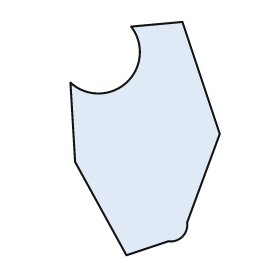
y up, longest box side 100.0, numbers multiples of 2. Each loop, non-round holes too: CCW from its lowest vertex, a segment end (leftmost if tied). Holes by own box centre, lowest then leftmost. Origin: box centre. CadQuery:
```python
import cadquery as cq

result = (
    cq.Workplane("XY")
    .moveTo(-8.0, -50.0)
    .lineTo(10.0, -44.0)
    .threePointArc((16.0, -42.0), (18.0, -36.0))
    .lineTo(32.0, 2.0)
    .lineTo(16.0, 50.0)
    .lineTo(-6.0, 48.0)
    .threePointArc((-8.0, 24.0), (-32.0, 24.0))
    .lineTo(-30.0, -10.0)
    .close()
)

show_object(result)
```